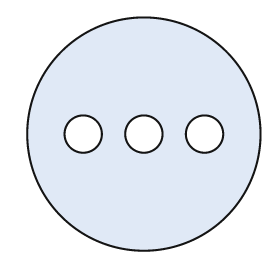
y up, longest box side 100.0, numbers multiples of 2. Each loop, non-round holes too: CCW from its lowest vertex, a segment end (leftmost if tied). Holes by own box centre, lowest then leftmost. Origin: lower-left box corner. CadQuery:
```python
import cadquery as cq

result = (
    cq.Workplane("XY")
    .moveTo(50.0, 50.0)
    .circle(50.0)
    .moveTo(24.0, 50.0)
    .circle(8.0)
    .moveTo(50.0, 50.0)
    .circle(8.0)
    .moveTo(76.0, 50.0)
    .circle(8.0)
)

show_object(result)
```